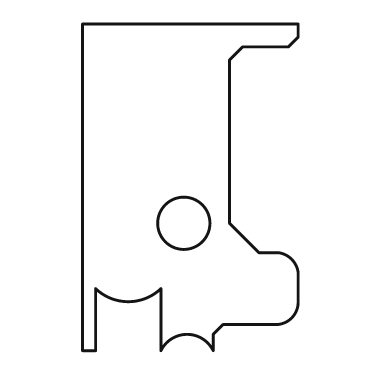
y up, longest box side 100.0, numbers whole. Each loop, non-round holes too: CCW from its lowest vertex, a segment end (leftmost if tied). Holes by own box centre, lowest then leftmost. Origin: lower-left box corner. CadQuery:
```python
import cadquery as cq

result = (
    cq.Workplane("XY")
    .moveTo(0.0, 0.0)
    .lineTo(4.0, 0.0)
    .lineTo(4.0, 19.0)
    .threePointArc((14.0, 15.0), (24.0, 19.0))
    .lineTo(24.0, 0.0)
    .threePointArc((32.0, 5.0), (40.0, 0.0))
    .lineTo(40.0, 5.0)
    .lineTo(43.0, 8.0)
    .lineTo(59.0, 8.0)
    .threePointArc((64.0, 10.0), (66.0, 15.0))
    .lineTo(66.0, 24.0)
    .threePointArc((64.0, 28.0), (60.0, 30.0))
    .lineTo(54.0, 30.0)
    .lineTo(45.0, 39.0)
    .lineTo(45.0, 89.0)
    .lineTo(49.0, 93.0)
    .lineTo(63.0, 93.0)
    .lineTo(66.0, 96.0)
    .lineTo(66.0, 100.0)
    .lineTo(0.0, 100.0)
    .close()
    .moveTo(31.0, 39.0)
    .circle(8.0)
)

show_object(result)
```